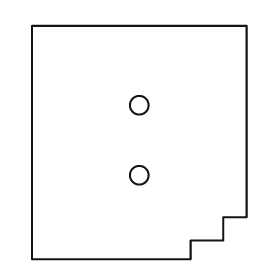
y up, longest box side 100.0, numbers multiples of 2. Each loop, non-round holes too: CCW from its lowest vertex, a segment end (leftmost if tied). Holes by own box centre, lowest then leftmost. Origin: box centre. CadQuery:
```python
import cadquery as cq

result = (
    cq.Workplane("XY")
    .moveTo(-46.0, -50.0)
    .lineTo(22.0, -50.0)
    .lineTo(22.0, -42.0)
    .lineTo(36.0, -42.0)
    .lineTo(36.0, -32.0)
    .lineTo(46.0, -32.0)
    .lineTo(46.0, 50.0)
    .lineTo(-46.0, 50.0)
    .close()
    .moveTo(0.0, -14.0)
    .circle(4.0)
    .moveTo(0.0, 16.0)
    .circle(4.0)
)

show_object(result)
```